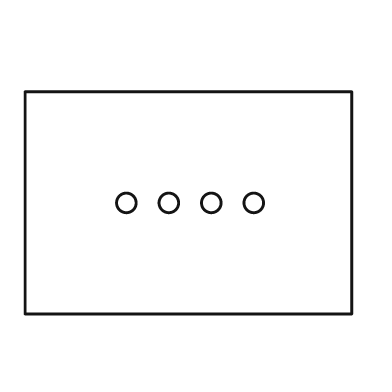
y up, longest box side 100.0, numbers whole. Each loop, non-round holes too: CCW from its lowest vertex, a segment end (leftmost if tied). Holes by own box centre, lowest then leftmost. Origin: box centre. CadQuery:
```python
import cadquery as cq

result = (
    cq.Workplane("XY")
    .moveTo(-50.0, -34.0)
    .lineTo(50.0, -34.0)
    .lineTo(50.0, 34.0)
    .lineTo(-50.0, 34.0)
    .close()
    .moveTo(-19.0, 0.0)
    .circle(3.0)
    .moveTo(-6.0, 0.0)
    .circle(3.0)
    .moveTo(7.0, 0.0)
    .circle(3.0)
    .moveTo(20.0, 0.0)
    .circle(3.0)
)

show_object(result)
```